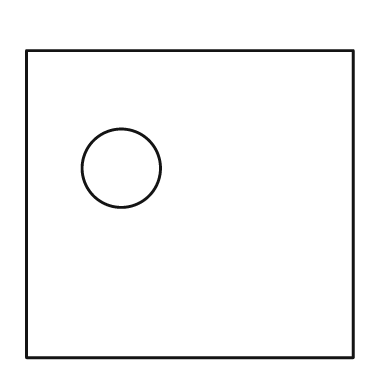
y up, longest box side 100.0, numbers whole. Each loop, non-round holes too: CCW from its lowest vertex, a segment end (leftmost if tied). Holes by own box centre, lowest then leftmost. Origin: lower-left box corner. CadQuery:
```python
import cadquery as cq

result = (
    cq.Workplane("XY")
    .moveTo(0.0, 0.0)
    .lineTo(100.0, 0.0)
    .lineTo(100.0, 94.0)
    .lineTo(0.0, 94.0)
    .close()
    .moveTo(29.0, 58.0)
    .circle(12.0)
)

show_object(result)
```